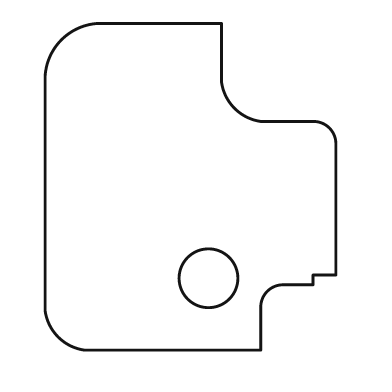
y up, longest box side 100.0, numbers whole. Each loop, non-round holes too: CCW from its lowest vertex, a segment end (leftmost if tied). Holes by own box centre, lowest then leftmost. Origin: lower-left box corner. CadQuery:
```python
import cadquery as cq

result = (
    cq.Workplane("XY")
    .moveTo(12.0, 0.0)
    .lineTo(66.0, 0.0)
    .lineTo(66.0, 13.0)
    .threePointArc((68.0, 18.0), (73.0, 20.0))
    .lineTo(82.0, 20.0)
    .lineTo(82.0, 23.0)
    .lineTo(89.0, 23.0)
    .lineTo(89.0, 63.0)
    .threePointArc((87.0, 68.0), (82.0, 70.0))
    .lineTo(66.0, 70.0)
    .threePointArc((58.0, 74.0), (54.0, 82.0))
    .lineTo(54.0, 100.0)
    .lineTo(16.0, 100.0)
    .threePointArc((5.0, 95.0), (0.0, 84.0))
    .lineTo(0.0, 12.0)
    .threePointArc((4.0, 4.0), (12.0, 0.0))
    .close()
    .moveTo(50.0, 22.0)
    .circle(9.0)
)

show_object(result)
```